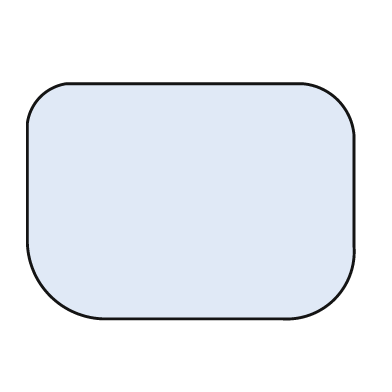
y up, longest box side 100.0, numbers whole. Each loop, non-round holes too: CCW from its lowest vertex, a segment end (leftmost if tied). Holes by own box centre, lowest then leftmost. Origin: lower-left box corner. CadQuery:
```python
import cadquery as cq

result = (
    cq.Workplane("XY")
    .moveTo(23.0, 0.0)
    .lineTo(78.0, 0.0)
    .threePointArc((94.0, 6.0), (100.0, 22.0))
    .lineTo(100.0, 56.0)
    .threePointArc((95.0, 67.0), (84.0, 72.0))
    .lineTo(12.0, 72.0)
    .threePointArc((4.0, 68.0), (0.0, 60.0))
    .lineTo(0.0, 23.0)
    .threePointArc((7.0, 7.0), (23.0, 0.0))
    .close()
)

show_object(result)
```